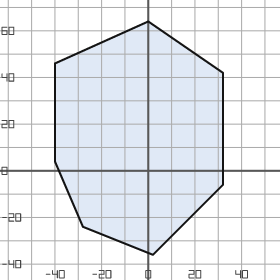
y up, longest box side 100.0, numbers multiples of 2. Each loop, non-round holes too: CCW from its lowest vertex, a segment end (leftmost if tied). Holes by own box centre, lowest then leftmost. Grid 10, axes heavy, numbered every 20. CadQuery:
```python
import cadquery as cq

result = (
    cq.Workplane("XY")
    .moveTo(2.0, -36.0)
    .lineTo(32.0, -6.0)
    .lineTo(32.0, 42.0)
    .lineTo(0.0, 64.0)
    .lineTo(-40.0, 46.0)
    .lineTo(-40.0, 4.0)
    .lineTo(-28.0, -24.0)
    .close()
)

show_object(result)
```